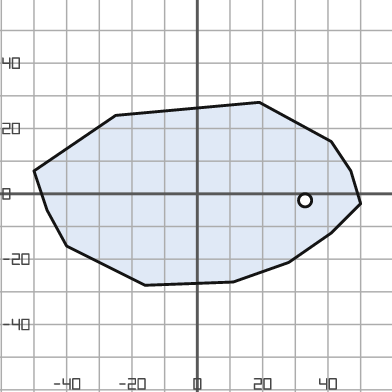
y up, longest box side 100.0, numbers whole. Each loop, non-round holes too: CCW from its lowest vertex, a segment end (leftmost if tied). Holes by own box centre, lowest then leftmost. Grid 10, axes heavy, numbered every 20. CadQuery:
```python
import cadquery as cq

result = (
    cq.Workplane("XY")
    .moveTo(-16.0, -28.0)
    .lineTo(11.0, -27.0)
    .lineTo(28.0, -21.0)
    .lineTo(41.0, -12.0)
    .lineTo(50.0, -3.0)
    .lineTo(47.0, 7.0)
    .lineTo(41.0, 16.0)
    .lineTo(19.0, 28.0)
    .lineTo(-25.0, 24.0)
    .lineTo(-50.0, 7.0)
    .lineTo(-46.0, -5.0)
    .lineTo(-40.0, -16.0)
    .close()
    .moveTo(33.0, -2.0)
    .circle(2.0)
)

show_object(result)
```